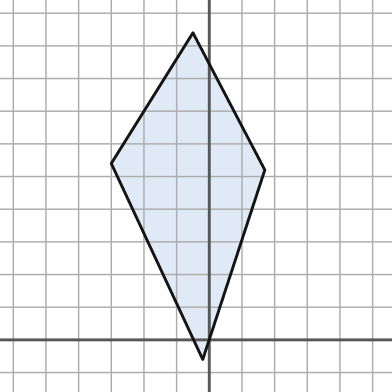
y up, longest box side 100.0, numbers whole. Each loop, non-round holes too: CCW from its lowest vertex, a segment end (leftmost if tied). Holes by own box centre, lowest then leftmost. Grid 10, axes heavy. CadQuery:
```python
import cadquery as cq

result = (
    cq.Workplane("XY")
    .moveTo(-2.0, -6.0)
    .lineTo(17.0, 52.0)
    .lineTo(-5.0, 94.0)
    .lineTo(-30.0, 54.0)
    .close()
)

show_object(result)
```